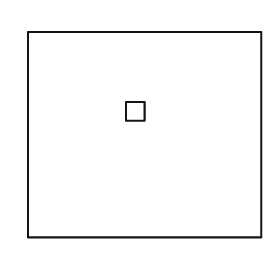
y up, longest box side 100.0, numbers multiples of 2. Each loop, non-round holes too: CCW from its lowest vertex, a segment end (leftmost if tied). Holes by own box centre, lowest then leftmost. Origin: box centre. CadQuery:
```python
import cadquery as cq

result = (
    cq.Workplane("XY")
    .moveTo(-50.0, -44.0)
    .lineTo(50.0, -44.0)
    .lineTo(50.0, 44.0)
    .lineTo(-50.0, 44.0)
    .close()
    .moveTo(-8.0, 6.0)
    .lineTo(0.0, 6.0)
    .lineTo(0.0, 14.0)
    .lineTo(-8.0, 14.0)
    .close()
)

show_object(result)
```